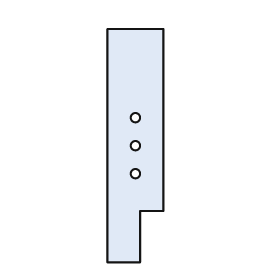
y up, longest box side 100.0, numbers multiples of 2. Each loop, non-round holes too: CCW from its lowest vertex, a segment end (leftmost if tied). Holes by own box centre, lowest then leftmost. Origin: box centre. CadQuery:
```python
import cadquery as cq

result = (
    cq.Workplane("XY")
    .moveTo(-12.0, -50.0)
    .lineTo(2.0, -50.0)
    .lineTo(2.0, -28.0)
    .lineTo(12.0, -28.0)
    .lineTo(12.0, 50.0)
    .lineTo(-12.0, 50.0)
    .close()
    .moveTo(0.0, -12.0)
    .circle(2.0)
    .moveTo(0.0, 0.0)
    .circle(2.0)
    .moveTo(0.0, 12.0)
    .circle(2.0)
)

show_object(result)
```